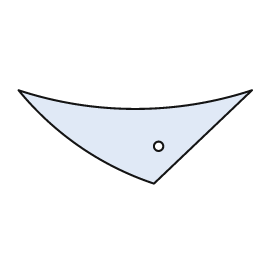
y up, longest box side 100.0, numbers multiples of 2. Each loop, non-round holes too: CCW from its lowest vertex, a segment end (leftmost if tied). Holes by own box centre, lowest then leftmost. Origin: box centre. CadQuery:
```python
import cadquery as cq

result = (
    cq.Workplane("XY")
    .moveTo(8.0, -20.0)
    .lineTo(50.0, 20.0)
    .threePointArc((0.0, 12.0), (-50.0, 20.0))
    .threePointArc((-24.0, -4.0), (8.0, -20.0))
    .close()
    .moveTo(10.0, -4.0)
    .circle(2.0)
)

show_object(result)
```